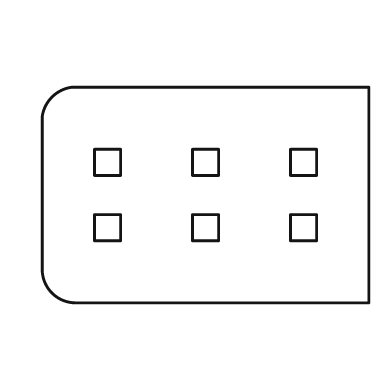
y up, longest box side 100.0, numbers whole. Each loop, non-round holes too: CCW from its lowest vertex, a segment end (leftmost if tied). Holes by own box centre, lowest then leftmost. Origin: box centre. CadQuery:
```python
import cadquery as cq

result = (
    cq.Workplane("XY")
    .moveTo(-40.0, -33.0)
    .lineTo(50.0, -33.0)
    .lineTo(50.0, 33.0)
    .lineTo(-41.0, 33.0)
    .threePointArc((-47.0, 30.0), (-50.0, 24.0))
    .lineTo(-50.0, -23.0)
    .threePointArc((-47.0, -30.0), (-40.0, -33.0))
    .close()
    .moveTo(-34.0, -14.0)
    .lineTo(-26.0, -14.0)
    .lineTo(-26.0, -6.0)
    .lineTo(-34.0, -6.0)
    .close()
    .moveTo(-4.0, -14.0)
    .lineTo(4.0, -14.0)
    .lineTo(4.0, -6.0)
    .lineTo(-4.0, -6.0)
    .close()
    .moveTo(26.0, -14.0)
    .lineTo(34.0, -14.0)
    .lineTo(34.0, -6.0)
    .lineTo(26.0, -6.0)
    .close()
    .moveTo(-34.0, 6.0)
    .lineTo(-26.0, 6.0)
    .lineTo(-26.0, 14.0)
    .lineTo(-34.0, 14.0)
    .close()
    .moveTo(-4.0, 6.0)
    .lineTo(4.0, 6.0)
    .lineTo(4.0, 14.0)
    .lineTo(-4.0, 14.0)
    .close()
    .moveTo(26.0, 6.0)
    .lineTo(34.0, 6.0)
    .lineTo(34.0, 14.0)
    .lineTo(26.0, 14.0)
    .close()
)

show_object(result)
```